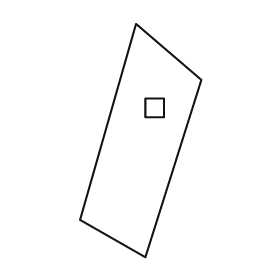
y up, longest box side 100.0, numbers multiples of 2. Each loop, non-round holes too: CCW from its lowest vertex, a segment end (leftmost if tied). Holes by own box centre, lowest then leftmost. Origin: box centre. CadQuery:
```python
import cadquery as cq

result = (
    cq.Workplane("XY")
    .moveTo(2.0, -50.0)
    .lineTo(26.0, 26.0)
    .lineTo(-2.0, 50.0)
    .lineTo(-26.0, -34.0)
    .close()
    .moveTo(2.0, 10.0)
    .lineTo(10.0, 10.0)
    .lineTo(10.0, 18.0)
    .lineTo(2.0, 18.0)
    .close()
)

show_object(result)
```